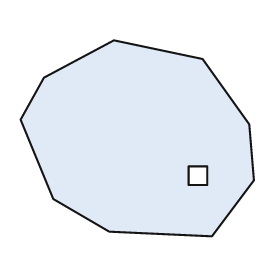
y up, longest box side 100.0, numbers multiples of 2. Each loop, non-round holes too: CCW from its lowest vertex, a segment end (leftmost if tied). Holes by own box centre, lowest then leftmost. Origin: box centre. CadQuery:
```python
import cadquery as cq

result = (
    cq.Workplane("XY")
    .moveTo(32.0, -42.0)
    .lineTo(50.0, -18.0)
    .lineTo(48.0, 6.0)
    .lineTo(28.0, 34.0)
    .lineTo(-10.0, 42.0)
    .lineTo(-40.0, 26.0)
    .lineTo(-50.0, 8.0)
    .lineTo(-36.0, -26.0)
    .lineTo(-12.0, -40.0)
    .close()
    .moveTo(22.0, -20.0)
    .lineTo(30.0, -20.0)
    .lineTo(30.0, -12.0)
    .lineTo(22.0, -12.0)
    .close()
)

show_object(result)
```